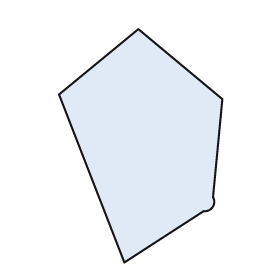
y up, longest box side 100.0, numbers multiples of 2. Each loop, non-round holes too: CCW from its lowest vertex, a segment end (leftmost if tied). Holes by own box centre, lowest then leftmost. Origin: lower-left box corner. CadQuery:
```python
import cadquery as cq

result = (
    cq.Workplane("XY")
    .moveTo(28.0, 0.0)
    .lineTo(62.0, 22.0)
    .threePointArc((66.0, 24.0), (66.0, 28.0))
    .lineTo(70.0, 70.0)
    .lineTo(34.0, 100.0)
    .lineTo(0.0, 72.0)
    .close()
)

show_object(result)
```